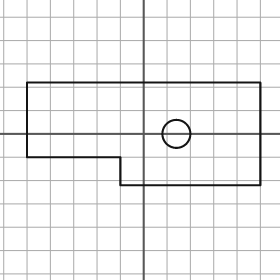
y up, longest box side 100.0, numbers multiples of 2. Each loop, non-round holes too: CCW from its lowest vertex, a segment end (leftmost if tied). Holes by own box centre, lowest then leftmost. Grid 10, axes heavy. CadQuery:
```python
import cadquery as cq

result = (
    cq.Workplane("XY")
    .moveTo(-10.0, -22.0)
    .lineTo(50.0, -22.0)
    .lineTo(50.0, 22.0)
    .lineTo(-50.0, 22.0)
    .lineTo(-50.0, -10.0)
    .lineTo(-10.0, -10.0)
    .close()
    .moveTo(14.0, 0.0)
    .circle(6.0)
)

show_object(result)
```